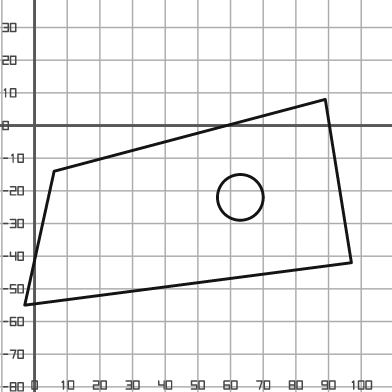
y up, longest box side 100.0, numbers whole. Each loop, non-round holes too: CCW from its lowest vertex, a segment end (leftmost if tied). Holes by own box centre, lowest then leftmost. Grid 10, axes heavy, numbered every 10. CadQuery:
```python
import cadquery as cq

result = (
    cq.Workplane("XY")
    .moveTo(-3.0, -55.0)
    .lineTo(97.0, -42.0)
    .lineTo(89.0, 8.0)
    .lineTo(6.0, -14.0)
    .close()
    .moveTo(63.0, -22.0)
    .circle(7.0)
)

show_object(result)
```